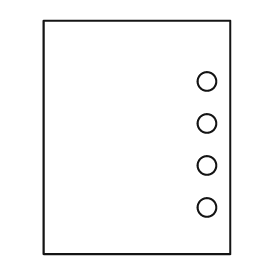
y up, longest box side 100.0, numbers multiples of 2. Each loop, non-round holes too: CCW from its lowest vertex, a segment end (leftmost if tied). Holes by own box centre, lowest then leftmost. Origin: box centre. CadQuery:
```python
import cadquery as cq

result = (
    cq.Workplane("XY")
    .moveTo(-40.0, -50.0)
    .lineTo(40.0, -50.0)
    .lineTo(40.0, 50.0)
    .lineTo(-40.0, 50.0)
    .close()
    .moveTo(30.0, -30.0)
    .circle(4.0)
    .moveTo(30.0, -12.0)
    .circle(4.0)
    .moveTo(30.0, 6.0)
    .circle(4.0)
    .moveTo(30.0, 24.0)
    .circle(4.0)
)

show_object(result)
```